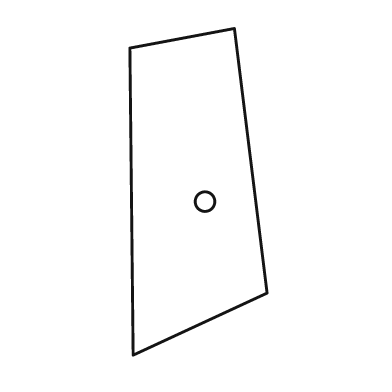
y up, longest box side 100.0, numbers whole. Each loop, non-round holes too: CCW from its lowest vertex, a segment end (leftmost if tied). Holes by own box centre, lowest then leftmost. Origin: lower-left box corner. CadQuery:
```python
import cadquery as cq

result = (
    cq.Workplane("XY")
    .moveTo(1.0, 0.0)
    .lineTo(42.0, 19.0)
    .lineTo(32.0, 100.0)
    .lineTo(0.0, 94.0)
    .close()
    .moveTo(23.0, 47.0)
    .circle(3.0)
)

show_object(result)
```